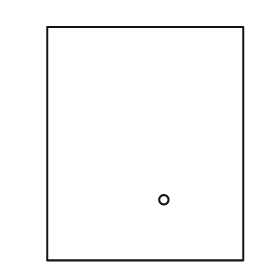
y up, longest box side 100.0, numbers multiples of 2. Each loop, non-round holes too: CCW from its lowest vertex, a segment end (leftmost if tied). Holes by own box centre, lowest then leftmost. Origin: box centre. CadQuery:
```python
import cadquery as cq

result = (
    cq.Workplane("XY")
    .moveTo(-42.0, -50.0)
    .lineTo(42.0, -50.0)
    .lineTo(42.0, 50.0)
    .lineTo(-42.0, 50.0)
    .close()
    .moveTo(8.0, -24.0)
    .circle(2.0)
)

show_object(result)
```